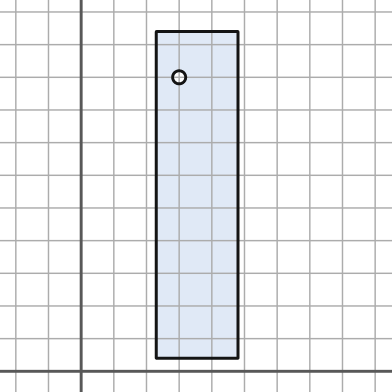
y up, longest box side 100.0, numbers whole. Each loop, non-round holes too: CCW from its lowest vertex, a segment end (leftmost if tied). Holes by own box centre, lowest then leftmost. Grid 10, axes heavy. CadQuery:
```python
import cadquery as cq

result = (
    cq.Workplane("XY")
    .moveTo(23.0, 4.0)
    .lineTo(48.0, 4.0)
    .lineTo(48.0, 104.0)
    .lineTo(23.0, 104.0)
    .close()
    .moveTo(30.0, 90.0)
    .circle(2.0)
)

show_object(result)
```